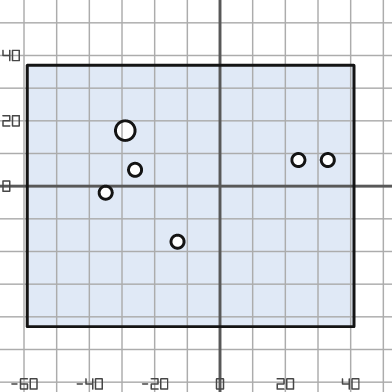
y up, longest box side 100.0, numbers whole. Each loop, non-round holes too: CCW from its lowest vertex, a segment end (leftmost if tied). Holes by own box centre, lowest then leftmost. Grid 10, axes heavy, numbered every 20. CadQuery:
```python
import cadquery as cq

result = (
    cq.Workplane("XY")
    .moveTo(-59.0, -43.0)
    .lineTo(41.0, -43.0)
    .lineTo(41.0, 37.0)
    .lineTo(-59.0, 37.0)
    .close()
    .moveTo(-13.0, -17.0)
    .circle(2.0)
    .moveTo(-35.0, -2.0)
    .circle(2.0)
    .moveTo(-26.0, 5.0)
    .circle(2.0)
    .moveTo(24.0, 8.0)
    .circle(2.0)
    .moveTo(33.0, 8.0)
    .circle(2.0)
    .moveTo(-29.0, 17.0)
    .circle(3.0)
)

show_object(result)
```